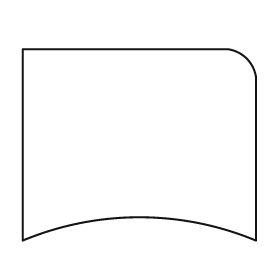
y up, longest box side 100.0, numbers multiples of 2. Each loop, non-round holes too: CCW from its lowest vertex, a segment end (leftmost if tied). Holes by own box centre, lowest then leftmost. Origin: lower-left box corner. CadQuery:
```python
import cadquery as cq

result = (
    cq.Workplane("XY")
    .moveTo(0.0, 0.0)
    .threePointArc((50.0, 10.0), (100.0, 0.0))
    .lineTo(100.0, 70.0)
    .threePointArc((96.0, 78.0), (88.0, 82.0))
    .lineTo(0.0, 82.0)
    .close()
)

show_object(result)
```